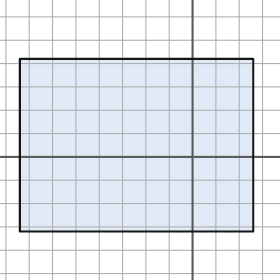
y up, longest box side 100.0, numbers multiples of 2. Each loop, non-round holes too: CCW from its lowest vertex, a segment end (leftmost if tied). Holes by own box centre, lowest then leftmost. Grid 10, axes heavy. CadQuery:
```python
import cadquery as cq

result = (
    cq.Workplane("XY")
    .moveTo(-74.0, -32.0)
    .lineTo(26.0, -32.0)
    .lineTo(26.0, 42.0)
    .lineTo(-74.0, 42.0)
    .close()
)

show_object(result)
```